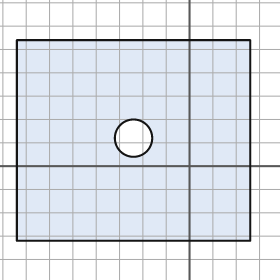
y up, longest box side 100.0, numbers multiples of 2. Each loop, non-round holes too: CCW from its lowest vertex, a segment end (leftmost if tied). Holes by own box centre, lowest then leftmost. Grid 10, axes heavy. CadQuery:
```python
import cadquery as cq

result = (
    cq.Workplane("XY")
    .moveTo(-74.0, -32.0)
    .lineTo(26.0, -32.0)
    .lineTo(26.0, 54.0)
    .lineTo(-74.0, 54.0)
    .close()
    .moveTo(-24.0, 12.0)
    .circle(8.0)
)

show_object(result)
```